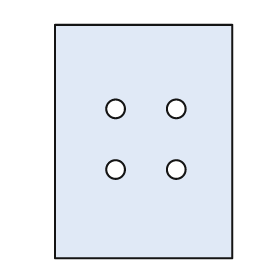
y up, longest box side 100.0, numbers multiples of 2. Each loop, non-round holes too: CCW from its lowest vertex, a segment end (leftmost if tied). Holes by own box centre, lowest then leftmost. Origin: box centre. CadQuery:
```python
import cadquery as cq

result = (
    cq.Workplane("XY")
    .moveTo(-38.0, -50.0)
    .lineTo(38.0, -50.0)
    .lineTo(38.0, 50.0)
    .lineTo(-38.0, 50.0)
    .close()
    .moveTo(-12.0, -12.0)
    .circle(4.0)
    .moveTo(14.0, -12.0)
    .circle(4.0)
    .moveTo(-12.0, 14.0)
    .circle(4.0)
    .moveTo(14.0, 14.0)
    .circle(4.0)
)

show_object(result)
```